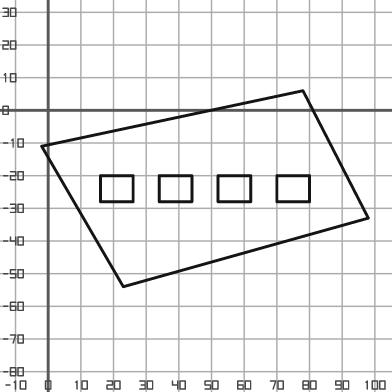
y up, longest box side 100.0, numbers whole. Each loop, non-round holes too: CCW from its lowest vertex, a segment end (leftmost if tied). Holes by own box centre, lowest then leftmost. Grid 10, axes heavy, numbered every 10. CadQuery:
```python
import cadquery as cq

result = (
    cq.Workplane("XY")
    .moveTo(23.0, -54.0)
    .lineTo(98.0, -33.0)
    .lineTo(78.0, 6.0)
    .lineTo(-2.0, -11.0)
    .close()
    .moveTo(16.0, -28.0)
    .lineTo(26.0, -28.0)
    .lineTo(26.0, -20.0)
    .lineTo(16.0, -20.0)
    .close()
    .moveTo(34.0, -28.0)
    .lineTo(44.0, -28.0)
    .lineTo(44.0, -20.0)
    .lineTo(34.0, -20.0)
    .close()
    .moveTo(52.0, -28.0)
    .lineTo(62.0, -28.0)
    .lineTo(62.0, -20.0)
    .lineTo(52.0, -20.0)
    .close()
    .moveTo(70.0, -28.0)
    .lineTo(80.0, -28.0)
    .lineTo(80.0, -20.0)
    .lineTo(70.0, -20.0)
    .close()
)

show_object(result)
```